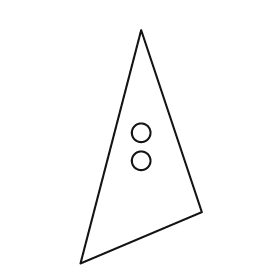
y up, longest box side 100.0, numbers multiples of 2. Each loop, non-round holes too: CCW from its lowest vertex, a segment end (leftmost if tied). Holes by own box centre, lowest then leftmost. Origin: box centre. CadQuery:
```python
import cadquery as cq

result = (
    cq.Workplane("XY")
    .moveTo(-26.0, -50.0)
    .lineTo(26.0, -28.0)
    .lineTo(0.0, 50.0)
    .close()
    .moveTo(0.0, -6.0)
    .circle(4.0)
    .moveTo(0.0, 6.0)
    .circle(4.0)
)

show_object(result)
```